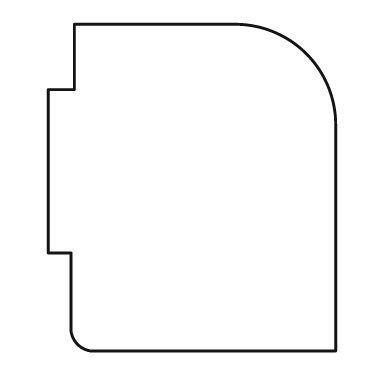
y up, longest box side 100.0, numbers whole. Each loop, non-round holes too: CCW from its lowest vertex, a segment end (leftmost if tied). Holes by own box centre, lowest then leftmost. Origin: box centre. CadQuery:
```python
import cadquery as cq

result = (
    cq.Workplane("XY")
    .moveTo(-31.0, -50.0)
    .lineTo(44.0, -50.0)
    .lineTo(44.0, 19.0)
    .threePointArc((35.0, 41.0), (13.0, 50.0))
    .lineTo(-36.0, 50.0)
    .lineTo(-36.0, 30.0)
    .lineTo(-44.0, 30.0)
    .lineTo(-44.0, -20.0)
    .lineTo(-37.0, -20.0)
    .lineTo(-37.0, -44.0)
    .threePointArc((-35.0, -48.0), (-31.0, -50.0))
    .close()
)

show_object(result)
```